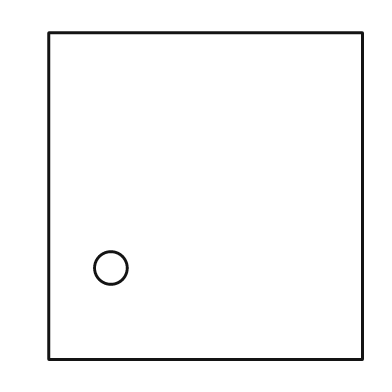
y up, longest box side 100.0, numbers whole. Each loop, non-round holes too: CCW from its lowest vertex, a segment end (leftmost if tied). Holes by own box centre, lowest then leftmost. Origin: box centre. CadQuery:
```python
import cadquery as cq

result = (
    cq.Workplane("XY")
    .moveTo(-48.0, -50.0)
    .lineTo(48.0, -50.0)
    .lineTo(48.0, 50.0)
    .lineTo(-48.0, 50.0)
    .close()
    .moveTo(-29.0, -22.0)
    .circle(5.0)
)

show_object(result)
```